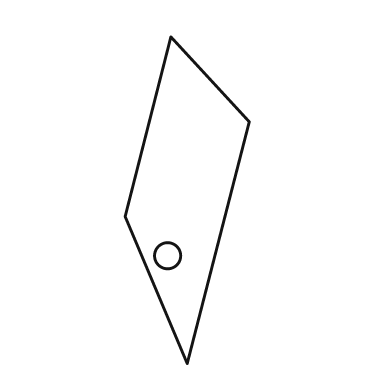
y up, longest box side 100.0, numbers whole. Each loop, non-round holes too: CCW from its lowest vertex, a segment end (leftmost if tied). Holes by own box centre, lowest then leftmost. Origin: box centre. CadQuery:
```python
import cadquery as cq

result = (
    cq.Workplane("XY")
    .moveTo(0.0, -50.0)
    .lineTo(19.0, 24.0)
    .lineTo(-5.0, 50.0)
    .lineTo(-19.0, -5.0)
    .close()
    .moveTo(-6.0, -17.0)
    .circle(4.0)
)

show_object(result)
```